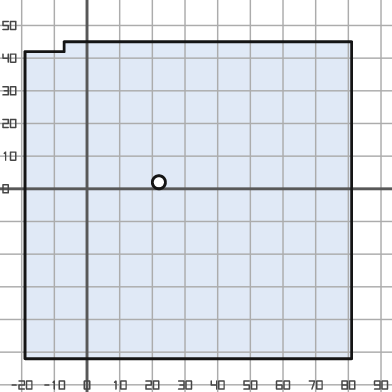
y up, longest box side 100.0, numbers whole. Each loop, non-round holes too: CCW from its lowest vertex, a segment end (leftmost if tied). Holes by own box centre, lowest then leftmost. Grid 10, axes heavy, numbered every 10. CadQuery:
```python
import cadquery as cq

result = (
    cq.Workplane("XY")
    .moveTo(-19.0, -52.0)
    .lineTo(81.0, -52.0)
    .lineTo(81.0, 45.0)
    .lineTo(-7.0, 45.0)
    .lineTo(-7.0, 42.0)
    .lineTo(-19.0, 42.0)
    .close()
    .moveTo(22.0, 2.0)
    .circle(2.0)
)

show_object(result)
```